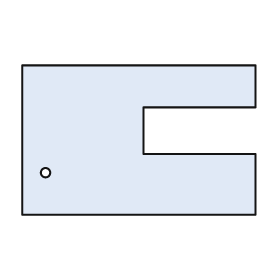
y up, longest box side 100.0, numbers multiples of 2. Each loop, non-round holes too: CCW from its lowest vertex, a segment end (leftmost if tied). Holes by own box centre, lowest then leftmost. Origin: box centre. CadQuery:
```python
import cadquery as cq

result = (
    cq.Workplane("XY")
    .moveTo(-50.0, -32.0)
    .lineTo(50.0, -32.0)
    .lineTo(50.0, -6.0)
    .lineTo(2.0, -6.0)
    .lineTo(2.0, 14.0)
    .lineTo(50.0, 14.0)
    .lineTo(50.0, 32.0)
    .lineTo(-50.0, 32.0)
    .close()
    .moveTo(-40.0, -14.0)
    .circle(2.0)
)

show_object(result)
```